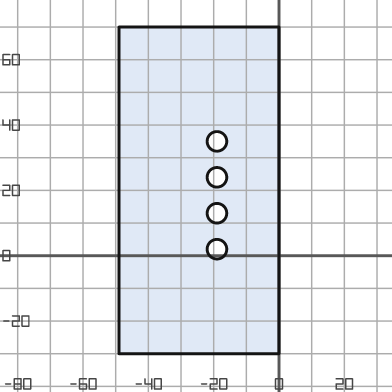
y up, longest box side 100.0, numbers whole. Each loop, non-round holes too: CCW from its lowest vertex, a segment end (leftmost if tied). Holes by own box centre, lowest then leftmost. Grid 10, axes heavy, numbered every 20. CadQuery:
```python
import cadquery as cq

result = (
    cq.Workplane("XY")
    .moveTo(-49.0, -30.0)
    .lineTo(0.0, -30.0)
    .lineTo(0.0, 70.0)
    .lineTo(-49.0, 70.0)
    .close()
    .moveTo(-19.0, 2.0)
    .circle(3.0)
    .moveTo(-19.0, 13.0)
    .circle(3.0)
    .moveTo(-19.0, 24.0)
    .circle(3.0)
    .moveTo(-19.0, 35.0)
    .circle(3.0)
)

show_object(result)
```